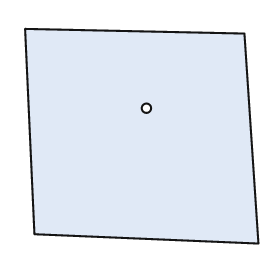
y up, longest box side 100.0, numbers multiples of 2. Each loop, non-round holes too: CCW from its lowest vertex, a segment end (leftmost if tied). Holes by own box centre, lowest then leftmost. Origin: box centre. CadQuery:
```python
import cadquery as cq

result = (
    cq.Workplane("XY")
    .moveTo(50.0, -46.0)
    .lineTo(44.0, 44.0)
    .lineTo(-50.0, 46.0)
    .lineTo(-46.0, -42.0)
    .close()
    .moveTo(2.0, 12.0)
    .circle(2.0)
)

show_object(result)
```